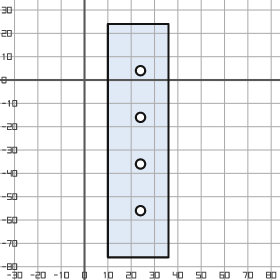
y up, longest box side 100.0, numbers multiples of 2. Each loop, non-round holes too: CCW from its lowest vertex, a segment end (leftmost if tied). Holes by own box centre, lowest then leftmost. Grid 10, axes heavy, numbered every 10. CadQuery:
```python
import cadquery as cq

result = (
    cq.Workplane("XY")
    .moveTo(10.0, -76.0)
    .lineTo(36.0, -76.0)
    .lineTo(36.0, 24.0)
    .lineTo(10.0, 24.0)
    .close()
    .moveTo(24.0, -56.0)
    .circle(2.0)
    .moveTo(24.0, -36.0)
    .circle(2.0)
    .moveTo(24.0, -16.0)
    .circle(2.0)
    .moveTo(24.0, 4.0)
    .circle(2.0)
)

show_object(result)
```